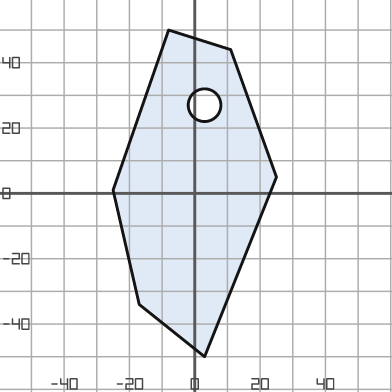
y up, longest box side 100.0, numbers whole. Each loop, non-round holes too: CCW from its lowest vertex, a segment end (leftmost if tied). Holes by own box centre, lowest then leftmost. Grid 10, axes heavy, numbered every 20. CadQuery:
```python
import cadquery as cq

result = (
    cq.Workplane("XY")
    .moveTo(3.0, -50.0)
    .lineTo(25.0, 5.0)
    .lineTo(11.0, 44.0)
    .lineTo(-8.0, 50.0)
    .lineTo(-25.0, 1.0)
    .lineTo(-17.0, -34.0)
    .close()
    .moveTo(3.0, 27.0)
    .circle(5.0)
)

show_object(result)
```